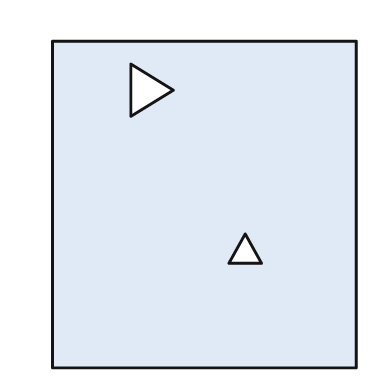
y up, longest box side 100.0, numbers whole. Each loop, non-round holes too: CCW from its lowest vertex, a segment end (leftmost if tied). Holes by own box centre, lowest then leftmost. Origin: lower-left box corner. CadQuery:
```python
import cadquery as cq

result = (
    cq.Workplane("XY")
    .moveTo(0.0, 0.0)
    .lineTo(93.0, 0.0)
    .lineTo(93.0, 100.0)
    .lineTo(0.0, 100.0)
    .close()
    .moveTo(54.0, 32.0)
    .lineTo(64.0, 32.0)
    .lineTo(59.0, 41.0)
    .close()
    .moveTo(24.0, 77.0)
    .lineTo(37.0, 85.0)
    .lineTo(24.0, 93.0)
    .close()
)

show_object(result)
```